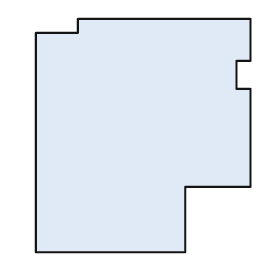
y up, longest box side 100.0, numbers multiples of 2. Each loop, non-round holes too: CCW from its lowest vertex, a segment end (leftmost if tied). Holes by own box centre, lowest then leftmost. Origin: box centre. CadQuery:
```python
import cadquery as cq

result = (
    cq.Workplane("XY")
    .moveTo(-46.0, -50.0)
    .lineTo(18.0, -50.0)
    .lineTo(18.0, -22.0)
    .lineTo(46.0, -22.0)
    .lineTo(46.0, 20.0)
    .lineTo(40.0, 20.0)
    .lineTo(40.0, 32.0)
    .lineTo(46.0, 32.0)
    .lineTo(46.0, 50.0)
    .lineTo(-28.0, 50.0)
    .lineTo(-28.0, 44.0)
    .lineTo(-46.0, 44.0)
    .close()
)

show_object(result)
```